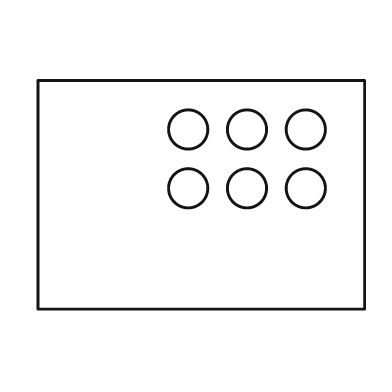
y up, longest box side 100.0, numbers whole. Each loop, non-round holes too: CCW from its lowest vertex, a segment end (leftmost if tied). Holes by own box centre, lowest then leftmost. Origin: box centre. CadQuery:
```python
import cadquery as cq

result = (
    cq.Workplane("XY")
    .moveTo(-50.0, -35.0)
    .lineTo(50.0, -35.0)
    .lineTo(50.0, 35.0)
    .lineTo(-50.0, 35.0)
    .close()
    .moveTo(-4.0, 2.0)
    .circle(6.0)
    .moveTo(14.0, 2.0)
    .circle(6.0)
    .moveTo(32.0, 2.0)
    .circle(6.0)
    .moveTo(-4.0, 20.0)
    .circle(6.0)
    .moveTo(14.0, 20.0)
    .circle(6.0)
    .moveTo(32.0, 20.0)
    .circle(6.0)
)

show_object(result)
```